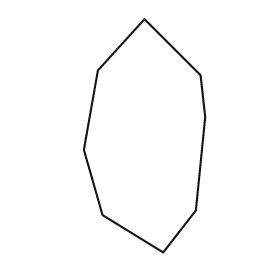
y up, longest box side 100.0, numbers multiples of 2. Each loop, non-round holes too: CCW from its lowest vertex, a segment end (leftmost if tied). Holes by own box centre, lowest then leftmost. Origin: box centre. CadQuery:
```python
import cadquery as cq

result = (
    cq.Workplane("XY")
    .moveTo(8.0, -50.0)
    .lineTo(22.0, -32.0)
    .lineTo(26.0, 8.0)
    .lineTo(24.0, 26.0)
    .lineTo(0.0, 50.0)
    .lineTo(-20.0, 28.0)
    .lineTo(-26.0, -6.0)
    .lineTo(-18.0, -34.0)
    .close()
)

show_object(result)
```